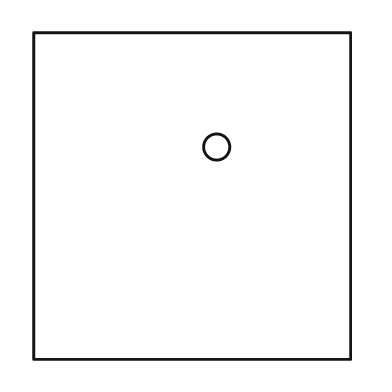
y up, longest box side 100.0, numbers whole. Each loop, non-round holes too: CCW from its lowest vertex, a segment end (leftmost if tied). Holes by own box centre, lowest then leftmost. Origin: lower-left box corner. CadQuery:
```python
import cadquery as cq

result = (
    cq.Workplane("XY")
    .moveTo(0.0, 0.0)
    .lineTo(97.0, 0.0)
    .lineTo(97.0, 100.0)
    .lineTo(0.0, 100.0)
    .close()
    .moveTo(56.0, 65.0)
    .circle(4.0)
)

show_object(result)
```